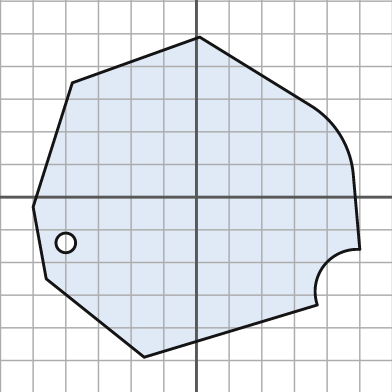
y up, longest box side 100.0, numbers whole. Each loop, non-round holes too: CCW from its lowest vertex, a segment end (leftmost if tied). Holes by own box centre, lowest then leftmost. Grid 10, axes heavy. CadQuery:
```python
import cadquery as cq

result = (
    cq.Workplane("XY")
    .moveTo(-16.0, -49.0)
    .lineTo(37.0, -33.0)
    .threePointArc((39.0, -21.0), (50.0, -16.0))
    .lineTo(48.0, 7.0)
    .threePointArc((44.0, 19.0), (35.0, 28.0))
    .lineTo(1.0, 49.0)
    .lineTo(-38.0, 35.0)
    .lineTo(-50.0, -3.0)
    .lineTo(-46.0, -25.0)
    .close()
    .moveTo(-40.0, -14.0)
    .circle(3.0)
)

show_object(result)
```